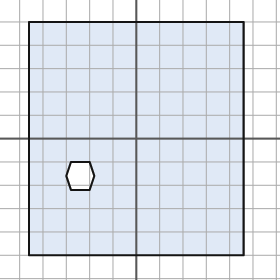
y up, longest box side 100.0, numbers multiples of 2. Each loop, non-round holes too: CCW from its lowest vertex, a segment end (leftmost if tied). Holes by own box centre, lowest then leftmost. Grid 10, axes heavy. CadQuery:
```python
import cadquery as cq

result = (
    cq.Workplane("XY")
    .moveTo(-46.0, -50.0)
    .lineTo(46.0, -50.0)
    .lineTo(46.0, 50.0)
    .lineTo(-46.0, 50.0)
    .close()
    .moveTo(-28.0, -22.0)
    .lineTo(-20.0, -22.0)
    .lineTo(-18.0, -16.0)
    .lineTo(-20.0, -10.0)
    .lineTo(-28.0, -10.0)
    .lineTo(-30.0, -16.0)
    .close()
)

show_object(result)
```